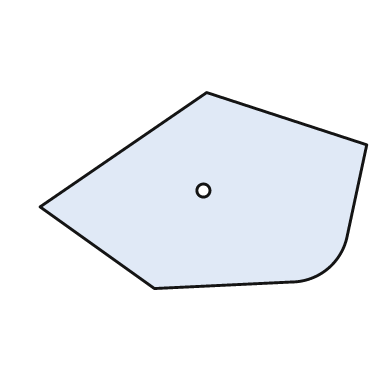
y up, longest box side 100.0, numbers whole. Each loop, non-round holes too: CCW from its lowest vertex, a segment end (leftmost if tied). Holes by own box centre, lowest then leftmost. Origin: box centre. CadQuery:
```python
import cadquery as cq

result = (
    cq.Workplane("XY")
    .moveTo(-15.0, -30.0)
    .lineTo(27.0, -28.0)
    .threePointArc((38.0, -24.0), (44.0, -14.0))
    .lineTo(50.0, 14.0)
    .lineTo(1.0, 30.0)
    .lineTo(-50.0, -5.0)
    .close()
    .moveTo(0.0, 0.0)
    .circle(2.0)
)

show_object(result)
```